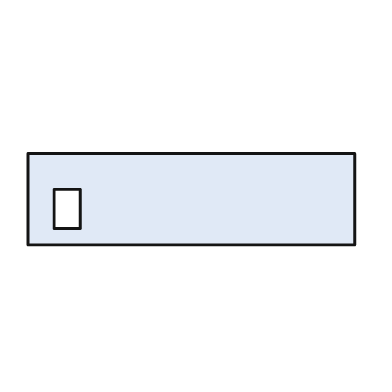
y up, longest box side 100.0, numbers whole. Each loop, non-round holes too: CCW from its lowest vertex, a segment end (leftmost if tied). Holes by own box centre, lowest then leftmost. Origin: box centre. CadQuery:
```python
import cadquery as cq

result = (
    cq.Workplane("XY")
    .moveTo(-50.0, -14.0)
    .lineTo(50.0, -14.0)
    .lineTo(50.0, 14.0)
    .lineTo(-50.0, 14.0)
    .close()
    .moveTo(-42.0, -9.0)
    .lineTo(-34.0, -9.0)
    .lineTo(-34.0, 3.0)
    .lineTo(-42.0, 3.0)
    .close()
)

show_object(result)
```